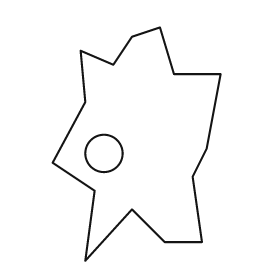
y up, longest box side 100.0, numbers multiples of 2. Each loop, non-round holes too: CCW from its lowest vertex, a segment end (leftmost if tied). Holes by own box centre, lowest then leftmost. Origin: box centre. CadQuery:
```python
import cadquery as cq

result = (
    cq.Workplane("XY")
    .moveTo(-22.0, -50.0)
    .lineTo(-2.0, -28.0)
    .lineTo(12.0, -42.0)
    .lineTo(28.0, -42.0)
    .lineTo(24.0, -14.0)
    .lineTo(30.0, -2.0)
    .lineTo(36.0, 30.0)
    .lineTo(16.0, 30.0)
    .lineTo(10.0, 50.0)
    .lineTo(-2.0, 46.0)
    .lineTo(-10.0, 34.0)
    .lineTo(-24.0, 40.0)
    .lineTo(-22.0, 18.0)
    .lineTo(-36.0, -8.0)
    .lineTo(-18.0, -20.0)
    .close()
    .moveTo(-14.0, -4.0)
    .circle(8.0)
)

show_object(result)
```